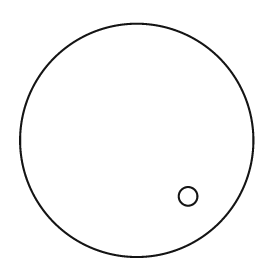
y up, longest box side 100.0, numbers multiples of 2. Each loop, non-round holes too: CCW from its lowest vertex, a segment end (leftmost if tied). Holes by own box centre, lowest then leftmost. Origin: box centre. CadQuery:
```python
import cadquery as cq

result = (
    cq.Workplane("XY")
    .moveTo(0.0, 0.0)
    .circle(50.0)
    .moveTo(22.0, -24.0)
    .circle(4.0)
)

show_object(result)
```